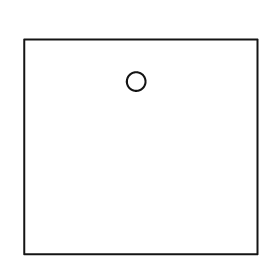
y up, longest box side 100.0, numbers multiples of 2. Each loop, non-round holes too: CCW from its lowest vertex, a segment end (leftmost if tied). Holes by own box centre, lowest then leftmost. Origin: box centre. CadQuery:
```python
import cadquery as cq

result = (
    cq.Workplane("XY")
    .moveTo(-50.0, -46.0)
    .lineTo(50.0, -46.0)
    .lineTo(50.0, 46.0)
    .lineTo(-50.0, 46.0)
    .close()
    .moveTo(-2.0, 28.0)
    .circle(4.0)
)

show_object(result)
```